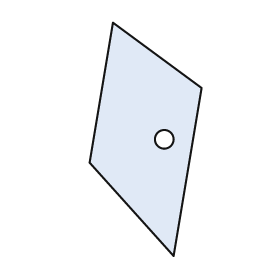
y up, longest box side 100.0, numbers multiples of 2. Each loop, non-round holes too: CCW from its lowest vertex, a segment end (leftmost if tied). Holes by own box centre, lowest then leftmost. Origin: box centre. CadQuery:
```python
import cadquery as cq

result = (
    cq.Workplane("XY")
    .moveTo(12.0, -50.0)
    .lineTo(24.0, 22.0)
    .lineTo(-14.0, 50.0)
    .lineTo(-24.0, -10.0)
    .close()
    .moveTo(8.0, 0.0)
    .circle(4.0)
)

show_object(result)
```